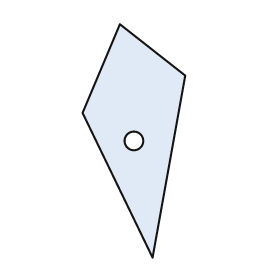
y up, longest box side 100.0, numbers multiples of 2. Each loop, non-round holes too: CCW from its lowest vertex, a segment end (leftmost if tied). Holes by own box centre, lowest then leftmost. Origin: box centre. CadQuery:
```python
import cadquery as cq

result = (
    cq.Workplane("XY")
    .moveTo(8.0, -50.0)
    .lineTo(22.0, 28.0)
    .lineTo(-6.0, 50.0)
    .lineTo(-22.0, 12.0)
    .close()
    .moveTo(0.0, 0.0)
    .circle(4.0)
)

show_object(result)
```